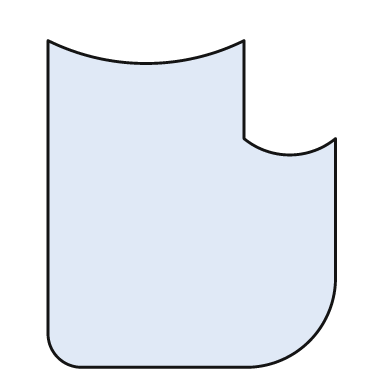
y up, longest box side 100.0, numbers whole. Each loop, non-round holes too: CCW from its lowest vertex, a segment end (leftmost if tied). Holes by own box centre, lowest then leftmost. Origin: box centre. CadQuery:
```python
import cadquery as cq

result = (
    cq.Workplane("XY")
    .moveTo(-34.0, -50.0)
    .lineTo(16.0, -50.0)
    .threePointArc((36.0, -42.0), (44.0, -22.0))
    .lineTo(44.0, 20.0)
    .threePointArc((30.0, 15.0), (16.0, 20.0))
    .lineTo(16.0, 50.0)
    .threePointArc((-14.0, 43.0), (-44.0, 50.0))
    .lineTo(-44.0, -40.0)
    .threePointArc((-41.0, -47.0), (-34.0, -50.0))
    .close()
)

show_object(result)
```